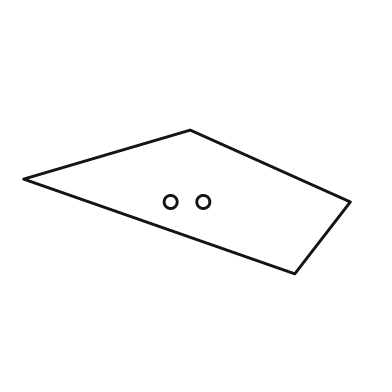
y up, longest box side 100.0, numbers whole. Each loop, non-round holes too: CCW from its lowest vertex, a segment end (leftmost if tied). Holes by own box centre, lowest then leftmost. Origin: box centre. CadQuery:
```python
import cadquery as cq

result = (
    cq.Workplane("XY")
    .moveTo(33.0, -22.0)
    .lineTo(50.0, 0.0)
    .lineTo(1.0, 22.0)
    .lineTo(-50.0, 7.0)
    .close()
    .moveTo(-5.0, 0.0)
    .circle(2.0)
    .moveTo(5.0, 0.0)
    .circle(2.0)
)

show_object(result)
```